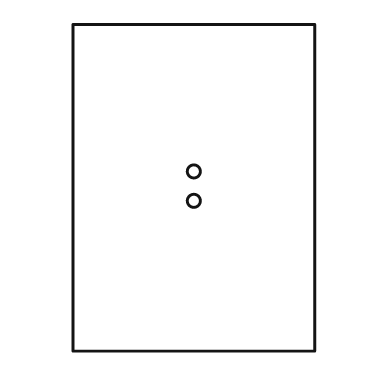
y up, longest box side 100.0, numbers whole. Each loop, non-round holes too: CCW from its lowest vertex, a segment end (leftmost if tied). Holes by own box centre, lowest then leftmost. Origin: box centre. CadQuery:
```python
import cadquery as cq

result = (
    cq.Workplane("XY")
    .moveTo(-37.0, -50.0)
    .lineTo(37.0, -50.0)
    .lineTo(37.0, 50.0)
    .lineTo(-37.0, 50.0)
    .close()
    .moveTo(0.0, -4.0)
    .circle(2.0)
    .moveTo(0.0, 5.0)
    .circle(2.0)
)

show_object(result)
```